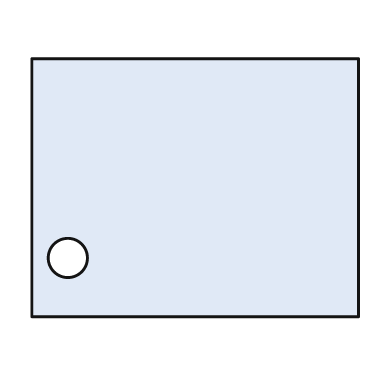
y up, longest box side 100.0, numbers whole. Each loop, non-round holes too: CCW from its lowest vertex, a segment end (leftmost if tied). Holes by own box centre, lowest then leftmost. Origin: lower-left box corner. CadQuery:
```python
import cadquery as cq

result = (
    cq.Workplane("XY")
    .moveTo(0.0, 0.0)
    .lineTo(100.0, 0.0)
    .lineTo(100.0, 79.0)
    .lineTo(0.0, 79.0)
    .close()
    .moveTo(11.0, 18.0)
    .circle(6.0)
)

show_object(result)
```